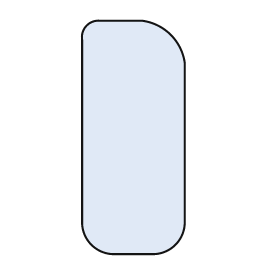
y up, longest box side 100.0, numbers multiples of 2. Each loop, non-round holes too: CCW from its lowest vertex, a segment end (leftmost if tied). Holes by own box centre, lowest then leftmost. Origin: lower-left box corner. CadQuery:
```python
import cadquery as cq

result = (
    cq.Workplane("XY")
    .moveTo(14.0, 0.0)
    .lineTo(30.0, 0.0)
    .threePointArc((40.0, 4.0), (44.0, 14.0))
    .lineTo(44.0, 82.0)
    .threePointArc((38.0, 94.0), (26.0, 100.0))
    .lineTo(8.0, 100.0)
    .threePointArc((2.0, 98.0), (0.0, 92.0))
    .lineTo(0.0, 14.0)
    .threePointArc((4.0, 4.0), (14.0, 0.0))
    .close()
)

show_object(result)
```